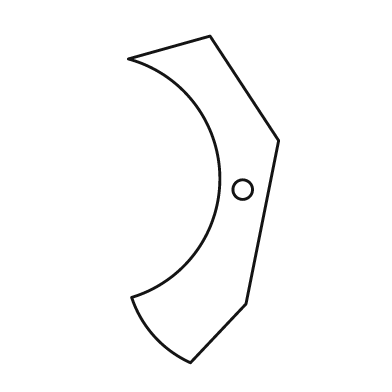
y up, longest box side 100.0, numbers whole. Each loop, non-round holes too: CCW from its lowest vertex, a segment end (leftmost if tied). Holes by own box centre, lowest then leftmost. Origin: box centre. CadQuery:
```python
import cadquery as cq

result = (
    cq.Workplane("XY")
    .moveTo(-4.0, -50.0)
    .lineTo(13.0, -32.0)
    .lineTo(23.0, 18.0)
    .lineTo(2.0, 50.0)
    .lineTo(-23.0, 43.0)
    .threePointArc((5.0, 7.0), (-22.0, -30.0))
    .threePointArc((-15.0, -42.0), (-4.0, -50.0))
    .close()
    .moveTo(12.0, 3.0)
    .circle(3.0)
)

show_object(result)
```